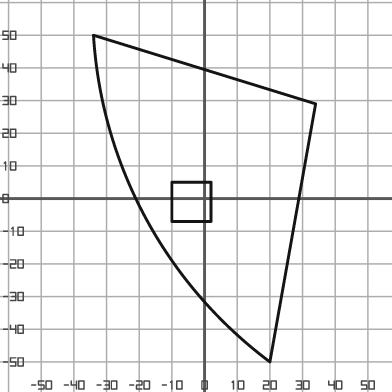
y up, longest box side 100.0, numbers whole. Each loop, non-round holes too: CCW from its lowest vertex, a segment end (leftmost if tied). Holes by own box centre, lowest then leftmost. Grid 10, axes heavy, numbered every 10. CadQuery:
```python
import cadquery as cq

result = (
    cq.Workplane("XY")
    .moveTo(20.0, -50.0)
    .lineTo(34.0, 29.0)
    .lineTo(-34.0, 50.0)
    .threePointArc((-18.0, -6.0), (20.0, -50.0))
    .close()
    .moveTo(-10.0, -7.0)
    .lineTo(2.0, -7.0)
    .lineTo(2.0, 5.0)
    .lineTo(-10.0, 5.0)
    .close()
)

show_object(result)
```